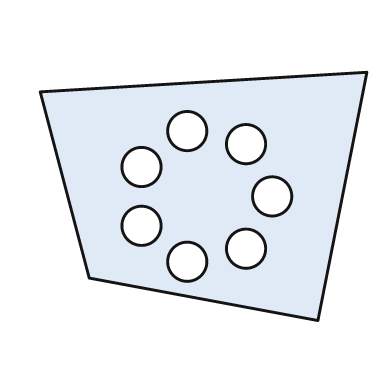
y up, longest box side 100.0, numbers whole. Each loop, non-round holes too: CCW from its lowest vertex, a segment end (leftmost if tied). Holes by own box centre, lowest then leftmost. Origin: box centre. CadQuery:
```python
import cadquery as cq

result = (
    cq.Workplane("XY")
    .moveTo(35.0, -38.0)
    .lineTo(50.0, 38.0)
    .lineTo(-50.0, 32.0)
    .lineTo(-35.0, -25.0)
    .close()
    .moveTo(-5.0, -20.0)
    .circle(6.0)
    .moveTo(13.0, -16.0)
    .circle(6.0)
    .moveTo(-19.0, -9.0)
    .circle(6.0)
    .moveTo(21.0, 0.0)
    .circle(6.0)
    .moveTo(-19.0, 9.0)
    .circle(6.0)
    .moveTo(13.0, 16.0)
    .circle(6.0)
    .moveTo(-5.0, 20.0)
    .circle(6.0)
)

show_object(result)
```